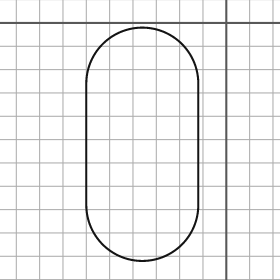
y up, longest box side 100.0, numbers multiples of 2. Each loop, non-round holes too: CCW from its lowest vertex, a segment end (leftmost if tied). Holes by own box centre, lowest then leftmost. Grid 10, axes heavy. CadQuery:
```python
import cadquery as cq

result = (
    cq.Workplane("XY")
    .moveTo(-60.0, -78.0)
    .threePointArc((-36.0, -102.0), (-12.0, -78.0))
    .lineTo(-12.0, -26.0)
    .threePointArc((-36.0, -2.0), (-60.0, -26.0))
    .close()
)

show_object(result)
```